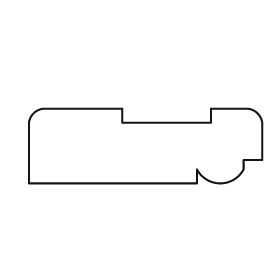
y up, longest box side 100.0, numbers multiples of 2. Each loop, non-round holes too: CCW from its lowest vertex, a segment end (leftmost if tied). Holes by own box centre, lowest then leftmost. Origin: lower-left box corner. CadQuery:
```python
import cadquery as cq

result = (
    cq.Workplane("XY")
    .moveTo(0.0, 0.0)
    .lineTo(72.0, 0.0)
    .lineTo(72.0, 6.0)
    .threePointArc((82.0, 0.0), (92.0, 6.0))
    .lineTo(92.0, 10.0)
    .lineTo(100.0, 10.0)
    .lineTo(100.0, 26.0)
    .threePointArc((98.0, 30.0), (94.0, 32.0))
    .lineTo(78.0, 32.0)
    .lineTo(78.0, 26.0)
    .lineTo(40.0, 26.0)
    .lineTo(40.0, 32.0)
    .lineTo(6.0, 32.0)
    .threePointArc((2.0, 30.0), (0.0, 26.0))
    .close()
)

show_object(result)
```